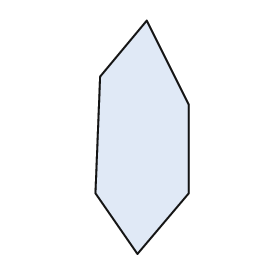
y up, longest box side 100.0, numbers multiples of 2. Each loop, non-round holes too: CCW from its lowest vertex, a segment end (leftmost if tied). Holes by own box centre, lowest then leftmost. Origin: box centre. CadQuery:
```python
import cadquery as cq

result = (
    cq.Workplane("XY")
    .moveTo(-2.0, -50.0)
    .lineTo(20.0, -24.0)
    .lineTo(20.0, 14.0)
    .lineTo(2.0, 50.0)
    .lineTo(-18.0, 26.0)
    .lineTo(-20.0, -24.0)
    .close()
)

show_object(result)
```